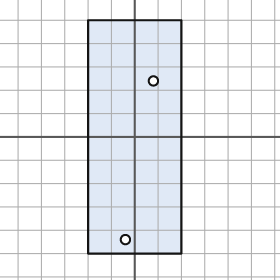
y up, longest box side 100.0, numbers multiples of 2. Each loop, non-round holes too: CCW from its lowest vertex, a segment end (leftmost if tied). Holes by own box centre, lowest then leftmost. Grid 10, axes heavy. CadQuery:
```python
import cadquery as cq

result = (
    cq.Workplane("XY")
    .moveTo(-20.0, -50.0)
    .lineTo(20.0, -50.0)
    .lineTo(20.0, 50.0)
    .lineTo(-20.0, 50.0)
    .close()
    .moveTo(-4.0, -44.0)
    .circle(2.0)
    .moveTo(8.0, 24.0)
    .circle(2.0)
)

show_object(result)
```